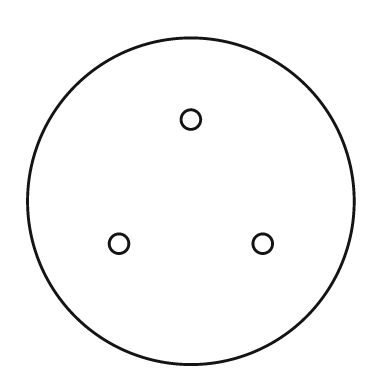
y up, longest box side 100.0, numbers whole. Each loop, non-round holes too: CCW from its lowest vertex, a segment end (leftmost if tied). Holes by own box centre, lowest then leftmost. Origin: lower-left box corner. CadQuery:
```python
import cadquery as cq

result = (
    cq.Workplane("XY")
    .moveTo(50.0, 50.0)
    .circle(50.0)
    .moveTo(28.0, 37.0)
    .circle(3.0)
    .moveTo(72.0, 37.0)
    .circle(3.0)
    .moveTo(50.0, 75.0)
    .circle(3.0)
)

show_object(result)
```